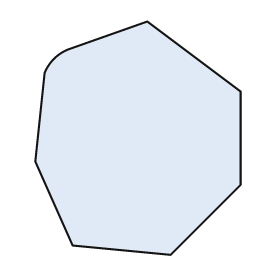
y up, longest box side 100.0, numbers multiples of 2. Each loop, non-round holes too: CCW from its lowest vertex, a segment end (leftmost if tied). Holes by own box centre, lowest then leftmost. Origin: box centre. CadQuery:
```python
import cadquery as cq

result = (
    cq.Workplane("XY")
    .moveTo(14.0, -50.0)
    .lineTo(44.0, -20.0)
    .lineTo(44.0, 20.0)
    .lineTo(4.0, 50.0)
    .lineTo(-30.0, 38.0)
    .threePointArc((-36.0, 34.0), (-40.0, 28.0))
    .lineTo(-44.0, -10.0)
    .lineTo(-28.0, -46.0)
    .close()
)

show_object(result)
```